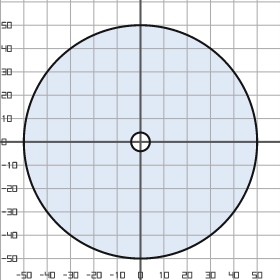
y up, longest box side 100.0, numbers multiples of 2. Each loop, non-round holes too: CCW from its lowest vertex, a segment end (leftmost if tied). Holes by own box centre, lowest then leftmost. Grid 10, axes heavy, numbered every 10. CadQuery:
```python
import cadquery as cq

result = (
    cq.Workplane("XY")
    .moveTo(0.0, 0.0)
    .circle(50.0)
    .moveTo(0.0, 0.0)
    .circle(4.0)
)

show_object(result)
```